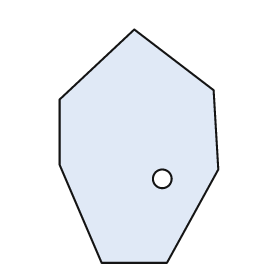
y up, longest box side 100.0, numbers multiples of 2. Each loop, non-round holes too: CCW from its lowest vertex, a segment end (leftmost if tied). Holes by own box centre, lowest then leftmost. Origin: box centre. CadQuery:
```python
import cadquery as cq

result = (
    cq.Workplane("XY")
    .moveTo(-16.0, -50.0)
    .lineTo(12.0, -50.0)
    .lineTo(34.0, -10.0)
    .lineTo(32.0, 24.0)
    .lineTo(-2.0, 50.0)
    .lineTo(-34.0, 20.0)
    .lineTo(-34.0, -8.0)
    .close()
    .moveTo(10.0, -14.0)
    .circle(4.0)
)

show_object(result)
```